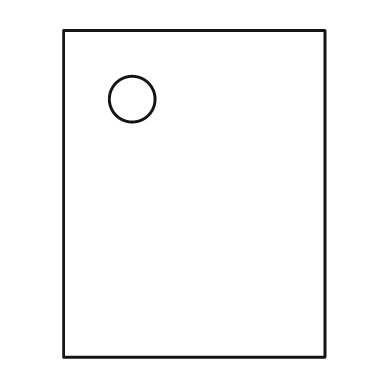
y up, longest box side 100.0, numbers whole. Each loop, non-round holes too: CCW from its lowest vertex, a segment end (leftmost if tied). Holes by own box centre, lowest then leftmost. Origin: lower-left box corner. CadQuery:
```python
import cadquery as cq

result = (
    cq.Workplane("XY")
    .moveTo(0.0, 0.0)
    .lineTo(80.0, 0.0)
    .lineTo(80.0, 100.0)
    .lineTo(0.0, 100.0)
    .close()
    .moveTo(21.0, 79.0)
    .circle(7.0)
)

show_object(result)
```